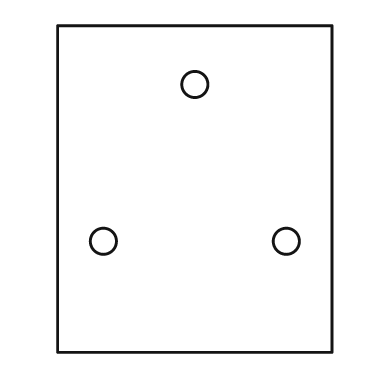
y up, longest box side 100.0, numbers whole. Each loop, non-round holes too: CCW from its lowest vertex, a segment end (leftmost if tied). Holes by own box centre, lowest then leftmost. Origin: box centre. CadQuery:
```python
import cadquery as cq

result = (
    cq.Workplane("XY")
    .moveTo(-42.0, -50.0)
    .lineTo(42.0, -50.0)
    .lineTo(42.0, 50.0)
    .lineTo(-42.0, 50.0)
    .close()
    .moveTo(-28.0, -16.0)
    .circle(4.0)
    .moveTo(28.0, -16.0)
    .circle(4.0)
    .moveTo(0.0, 32.0)
    .circle(4.0)
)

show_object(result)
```